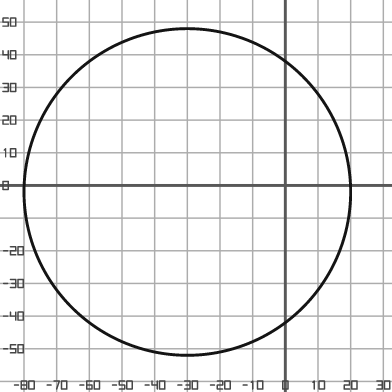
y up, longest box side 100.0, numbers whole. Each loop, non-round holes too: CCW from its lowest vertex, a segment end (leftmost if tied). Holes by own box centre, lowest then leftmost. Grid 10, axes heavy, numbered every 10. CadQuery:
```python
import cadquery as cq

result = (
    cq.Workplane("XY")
    .moveTo(-30.0, -2.0)
    .circle(50.0)
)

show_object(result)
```